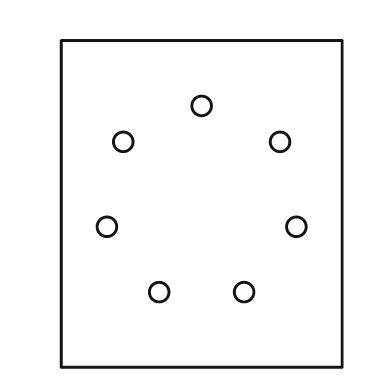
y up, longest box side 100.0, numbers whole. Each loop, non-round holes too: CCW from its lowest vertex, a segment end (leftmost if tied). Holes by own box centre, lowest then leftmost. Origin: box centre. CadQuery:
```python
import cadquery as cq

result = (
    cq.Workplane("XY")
    .moveTo(-43.0, -50.0)
    .lineTo(43.0, -50.0)
    .lineTo(43.0, 50.0)
    .lineTo(-43.0, 50.0)
    .close()
    .moveTo(-13.0, -27.0)
    .circle(3.0)
    .moveTo(13.0, -27.0)
    .circle(3.0)
    .moveTo(-29.0, -7.0)
    .circle(3.0)
    .moveTo(29.0, -7.0)
    .circle(3.0)
    .moveTo(-24.0, 19.0)
    .circle(3.0)
    .moveTo(24.0, 19.0)
    .circle(3.0)
    .moveTo(0.0, 30.0)
    .circle(3.0)
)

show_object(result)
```